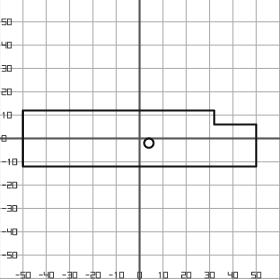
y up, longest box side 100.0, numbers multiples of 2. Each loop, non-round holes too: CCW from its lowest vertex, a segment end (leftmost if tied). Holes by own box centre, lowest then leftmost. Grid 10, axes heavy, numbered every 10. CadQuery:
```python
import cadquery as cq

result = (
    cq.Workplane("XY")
    .moveTo(-50.0, -12.0)
    .lineTo(50.0, -12.0)
    .lineTo(50.0, 6.0)
    .lineTo(32.0, 6.0)
    .lineTo(32.0, 12.0)
    .lineTo(-50.0, 12.0)
    .close()
    .moveTo(4.0, -2.0)
    .circle(2.0)
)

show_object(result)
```